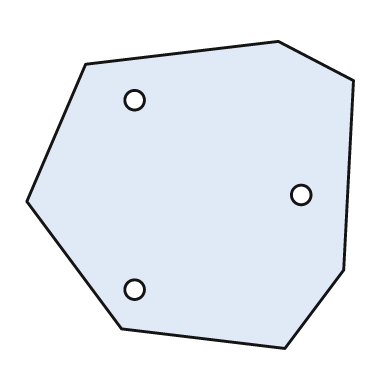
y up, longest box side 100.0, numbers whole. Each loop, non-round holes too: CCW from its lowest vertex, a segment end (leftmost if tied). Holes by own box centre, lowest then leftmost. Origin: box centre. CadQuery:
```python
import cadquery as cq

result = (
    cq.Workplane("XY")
    .moveTo(29.0, -47.0)
    .lineTo(47.0, -23.0)
    .lineTo(50.0, 35.0)
    .lineTo(27.0, 47.0)
    .lineTo(-32.0, 40.0)
    .lineTo(-50.0, -2.0)
    .lineTo(-21.0, -41.0)
    .close()
    .moveTo(-17.0, -29.0)
    .circle(3.0)
    .moveTo(34.0, 0.0)
    .circle(3.0)
    .moveTo(-17.0, 29.0)
    .circle(3.0)
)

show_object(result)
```